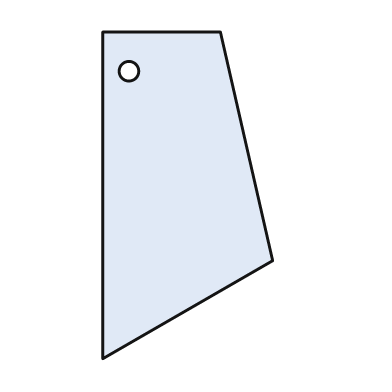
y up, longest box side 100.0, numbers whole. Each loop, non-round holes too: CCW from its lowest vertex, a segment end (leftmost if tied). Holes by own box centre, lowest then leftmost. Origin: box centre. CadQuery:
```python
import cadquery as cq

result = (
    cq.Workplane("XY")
    .moveTo(-26.0, -50.0)
    .lineTo(26.0, -20.0)
    .lineTo(10.0, 50.0)
    .lineTo(-26.0, 50.0)
    .close()
    .moveTo(-18.0, 38.0)
    .circle(3.0)
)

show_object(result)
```